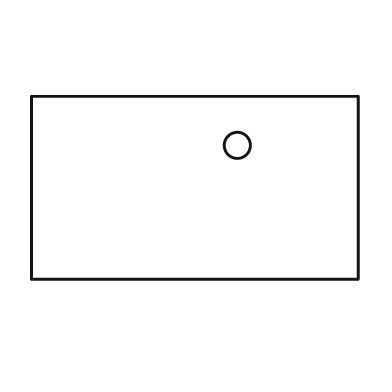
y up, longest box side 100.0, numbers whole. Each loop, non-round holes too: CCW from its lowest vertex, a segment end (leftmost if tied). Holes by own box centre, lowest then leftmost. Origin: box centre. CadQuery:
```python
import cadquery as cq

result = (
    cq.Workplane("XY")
    .moveTo(-50.0, -28.0)
    .lineTo(50.0, -28.0)
    .lineTo(50.0, 28.0)
    .lineTo(-50.0, 28.0)
    .close()
    .moveTo(13.0, 13.0)
    .circle(4.0)
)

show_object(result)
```